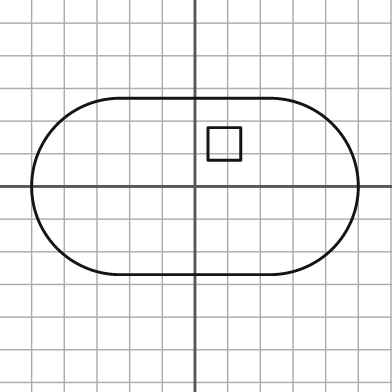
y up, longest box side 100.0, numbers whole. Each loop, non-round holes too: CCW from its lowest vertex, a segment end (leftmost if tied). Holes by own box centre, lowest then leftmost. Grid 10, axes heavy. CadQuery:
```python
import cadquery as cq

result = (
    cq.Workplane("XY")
    .moveTo(-23.0, -27.0)
    .lineTo(23.0, -27.0)
    .threePointArc((50.0, 0.0), (23.0, 27.0))
    .lineTo(-23.0, 27.0)
    .threePointArc((-50.0, 0.0), (-23.0, -27.0))
    .close()
    .moveTo(4.0, 8.0)
    .lineTo(14.0, 8.0)
    .lineTo(14.0, 18.0)
    .lineTo(4.0, 18.0)
    .close()
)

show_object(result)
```